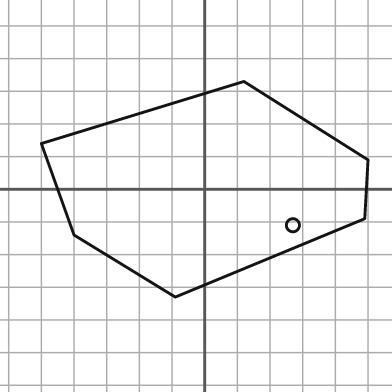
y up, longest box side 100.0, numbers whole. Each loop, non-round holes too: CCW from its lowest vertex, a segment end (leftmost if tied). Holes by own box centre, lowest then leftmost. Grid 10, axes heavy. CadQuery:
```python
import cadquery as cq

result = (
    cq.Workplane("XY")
    .moveTo(-9.0, -33.0)
    .lineTo(49.0, -9.0)
    .lineTo(50.0, 9.0)
    .lineTo(12.0, 33.0)
    .lineTo(-50.0, 14.0)
    .lineTo(-40.0, -14.0)
    .close()
    .moveTo(27.0, -11.0)
    .circle(2.0)
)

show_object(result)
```